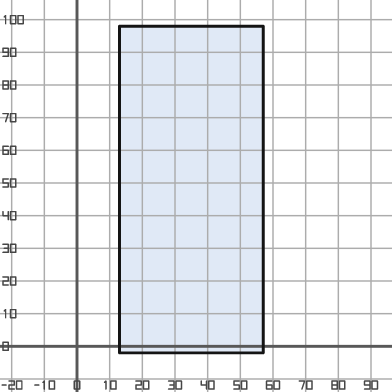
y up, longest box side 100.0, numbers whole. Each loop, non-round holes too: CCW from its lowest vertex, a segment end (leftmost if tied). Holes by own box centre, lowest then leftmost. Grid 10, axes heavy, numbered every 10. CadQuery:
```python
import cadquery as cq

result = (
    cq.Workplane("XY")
    .moveTo(13.0, -2.0)
    .lineTo(57.0, -2.0)
    .lineTo(57.0, 98.0)
    .lineTo(13.0, 98.0)
    .close()
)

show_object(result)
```